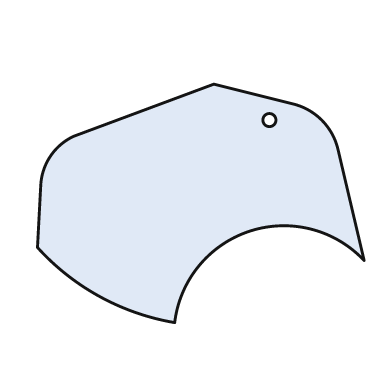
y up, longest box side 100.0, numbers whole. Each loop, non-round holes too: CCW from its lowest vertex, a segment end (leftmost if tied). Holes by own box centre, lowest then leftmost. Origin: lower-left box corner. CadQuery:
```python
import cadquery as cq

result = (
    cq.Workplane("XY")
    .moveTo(42.0, 0.0)
    .threePointArc((65.0, 28.0), (100.0, 19.0))
    .lineTo(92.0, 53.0)
    .threePointArc((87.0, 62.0), (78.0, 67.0))
    .lineTo(54.0, 73.0)
    .lineTo(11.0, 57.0)
    .threePointArc((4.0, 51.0), (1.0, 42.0))
    .lineTo(0.0, 23.0)
    .threePointArc((19.0, 8.0), (42.0, 0.0))
    .close()
    .moveTo(71.0, 62.0)
    .circle(2.0)
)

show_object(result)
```